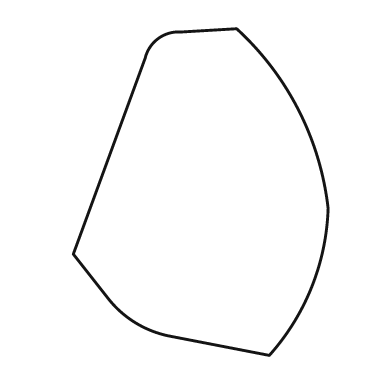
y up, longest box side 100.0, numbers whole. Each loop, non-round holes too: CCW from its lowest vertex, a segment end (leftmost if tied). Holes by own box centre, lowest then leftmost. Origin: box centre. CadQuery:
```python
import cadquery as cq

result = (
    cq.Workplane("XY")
    .moveTo(21.0, -50.0)
    .threePointArc((34.0, -29.0), (39.0, -5.0))
    .threePointArc((30.0, 25.0), (11.0, 50.0))
    .lineTo(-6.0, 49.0)
    .threePointArc((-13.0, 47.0), (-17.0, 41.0))
    .lineTo(-39.0, -19.0)
    .lineTo(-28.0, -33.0)
    .threePointArc((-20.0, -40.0), (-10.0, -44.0))
    .close()
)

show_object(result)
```